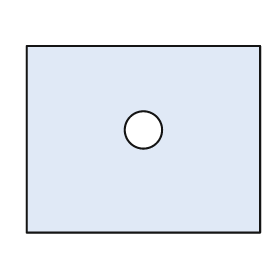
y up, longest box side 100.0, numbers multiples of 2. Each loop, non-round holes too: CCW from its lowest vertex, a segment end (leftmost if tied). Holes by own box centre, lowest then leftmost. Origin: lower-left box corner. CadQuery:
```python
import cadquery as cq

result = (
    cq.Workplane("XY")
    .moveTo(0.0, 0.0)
    .lineTo(100.0, 0.0)
    .lineTo(100.0, 80.0)
    .lineTo(0.0, 80.0)
    .close()
    .moveTo(50.0, 44.0)
    .circle(8.0)
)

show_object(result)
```